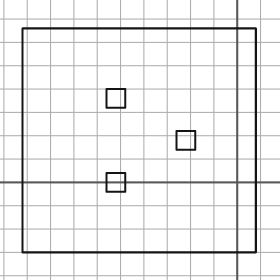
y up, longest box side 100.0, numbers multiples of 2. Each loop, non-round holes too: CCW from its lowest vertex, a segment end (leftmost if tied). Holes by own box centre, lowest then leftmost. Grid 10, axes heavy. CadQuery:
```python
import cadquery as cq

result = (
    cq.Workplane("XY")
    .moveTo(-92.0, -30.0)
    .lineTo(8.0, -30.0)
    .lineTo(8.0, 66.0)
    .lineTo(-92.0, 66.0)
    .close()
    .moveTo(-56.0, -4.0)
    .lineTo(-48.0, -4.0)
    .lineTo(-48.0, 4.0)
    .lineTo(-56.0, 4.0)
    .close()
    .moveTo(-26.0, 14.0)
    .lineTo(-18.0, 14.0)
    .lineTo(-18.0, 22.0)
    .lineTo(-26.0, 22.0)
    .close()
    .moveTo(-56.0, 32.0)
    .lineTo(-48.0, 32.0)
    .lineTo(-48.0, 40.0)
    .lineTo(-56.0, 40.0)
    .close()
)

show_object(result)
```